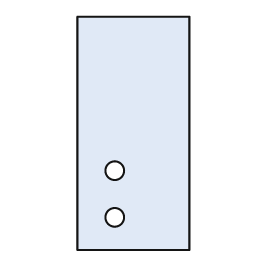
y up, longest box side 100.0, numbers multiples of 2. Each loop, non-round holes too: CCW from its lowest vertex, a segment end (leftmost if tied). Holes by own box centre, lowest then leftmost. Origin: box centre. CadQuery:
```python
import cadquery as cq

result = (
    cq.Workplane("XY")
    .moveTo(-24.0, -50.0)
    .lineTo(24.0, -50.0)
    .lineTo(24.0, 50.0)
    .lineTo(-24.0, 50.0)
    .close()
    .moveTo(-8.0, -36.0)
    .circle(4.0)
    .moveTo(-8.0, -16.0)
    .circle(4.0)
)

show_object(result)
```